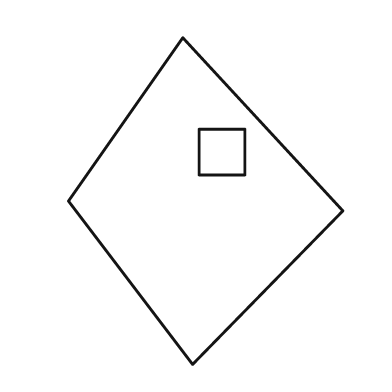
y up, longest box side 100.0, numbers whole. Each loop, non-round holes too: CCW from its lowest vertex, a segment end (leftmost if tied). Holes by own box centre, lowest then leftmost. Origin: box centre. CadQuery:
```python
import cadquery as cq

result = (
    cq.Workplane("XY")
    .moveTo(-4.0, -50.0)
    .lineTo(42.0, -3.0)
    .lineTo(-7.0, 50.0)
    .lineTo(-42.0, 0.0)
    .close()
    .moveTo(-2.0, 8.0)
    .lineTo(12.0, 8.0)
    .lineTo(12.0, 22.0)
    .lineTo(-2.0, 22.0)
    .close()
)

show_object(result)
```